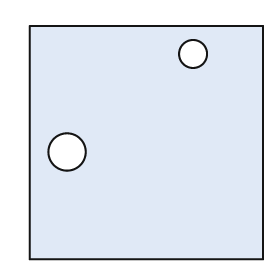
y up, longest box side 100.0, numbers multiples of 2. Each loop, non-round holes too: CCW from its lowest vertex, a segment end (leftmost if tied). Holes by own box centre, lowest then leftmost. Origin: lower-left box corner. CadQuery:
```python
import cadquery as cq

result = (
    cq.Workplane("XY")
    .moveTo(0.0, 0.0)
    .lineTo(100.0, 0.0)
    .lineTo(100.0, 100.0)
    .lineTo(0.0, 100.0)
    .close()
    .moveTo(16.0, 46.0)
    .circle(8.0)
    .moveTo(70.0, 88.0)
    .circle(6.0)
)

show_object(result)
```